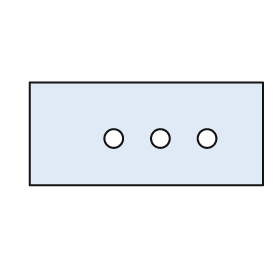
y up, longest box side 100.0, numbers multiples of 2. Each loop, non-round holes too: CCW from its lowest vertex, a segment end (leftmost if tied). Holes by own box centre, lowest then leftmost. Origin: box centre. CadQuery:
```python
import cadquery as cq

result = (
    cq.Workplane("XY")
    .moveTo(-50.0, -22.0)
    .lineTo(50.0, -22.0)
    .lineTo(50.0, 22.0)
    .lineTo(-50.0, 22.0)
    .close()
    .moveTo(-14.0, -2.0)
    .circle(4.0)
    .moveTo(6.0, -2.0)
    .circle(4.0)
    .moveTo(26.0, -2.0)
    .circle(4.0)
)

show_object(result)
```